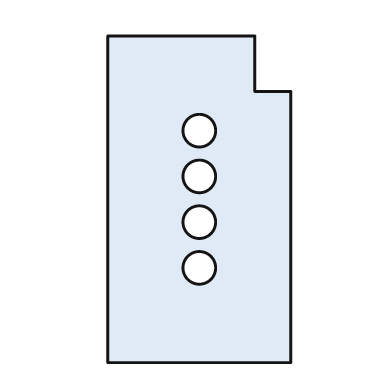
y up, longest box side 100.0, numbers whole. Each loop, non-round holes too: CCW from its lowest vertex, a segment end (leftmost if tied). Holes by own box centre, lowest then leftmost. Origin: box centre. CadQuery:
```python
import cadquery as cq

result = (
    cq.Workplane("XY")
    .moveTo(-28.0, -50.0)
    .lineTo(28.0, -50.0)
    .lineTo(28.0, 33.0)
    .lineTo(17.0, 33.0)
    .lineTo(17.0, 50.0)
    .lineTo(-28.0, 50.0)
    .close()
    .moveTo(0.0, -21.0)
    .circle(5.0)
    .moveTo(0.0, -7.0)
    .circle(5.0)
    .moveTo(0.0, 7.0)
    .circle(5.0)
    .moveTo(0.0, 21.0)
    .circle(5.0)
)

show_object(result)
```